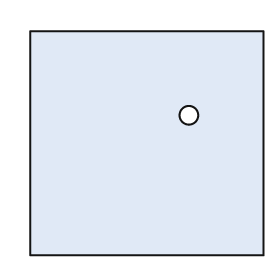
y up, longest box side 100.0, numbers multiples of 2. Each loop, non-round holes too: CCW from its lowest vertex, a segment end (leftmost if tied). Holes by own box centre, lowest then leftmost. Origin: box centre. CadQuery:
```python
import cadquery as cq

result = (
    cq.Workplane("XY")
    .moveTo(-50.0, -48.0)
    .lineTo(50.0, -48.0)
    .lineTo(50.0, 48.0)
    .lineTo(-50.0, 48.0)
    .close()
    .moveTo(18.0, 12.0)
    .circle(4.0)
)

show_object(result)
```